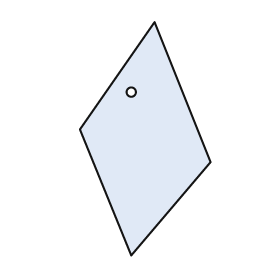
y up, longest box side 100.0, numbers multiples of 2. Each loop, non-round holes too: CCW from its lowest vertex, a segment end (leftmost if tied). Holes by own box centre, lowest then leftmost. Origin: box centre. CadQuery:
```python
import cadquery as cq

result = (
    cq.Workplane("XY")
    .moveTo(-6.0, -50.0)
    .lineTo(28.0, -10.0)
    .lineTo(4.0, 50.0)
    .lineTo(-28.0, 4.0)
    .close()
    .moveTo(-6.0, 20.0)
    .circle(2.0)
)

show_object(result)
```